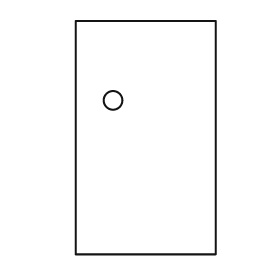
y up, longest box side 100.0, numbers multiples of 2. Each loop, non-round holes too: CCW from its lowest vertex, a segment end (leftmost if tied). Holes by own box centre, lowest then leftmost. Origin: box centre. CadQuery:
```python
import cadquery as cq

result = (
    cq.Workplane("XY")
    .moveTo(-30.0, -50.0)
    .lineTo(30.0, -50.0)
    .lineTo(30.0, 50.0)
    .lineTo(-30.0, 50.0)
    .close()
    .moveTo(-14.0, 16.0)
    .circle(4.0)
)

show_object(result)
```